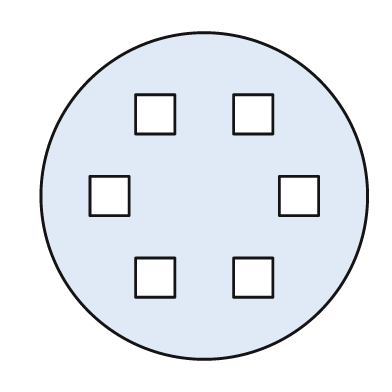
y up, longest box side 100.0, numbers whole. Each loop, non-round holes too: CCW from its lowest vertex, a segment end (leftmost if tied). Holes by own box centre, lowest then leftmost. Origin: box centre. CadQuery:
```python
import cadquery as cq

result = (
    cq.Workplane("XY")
    .moveTo(0.0, 0.0)
    .circle(50.0)
    .moveTo(-21.0, -31.0)
    .lineTo(-9.0, -31.0)
    .lineTo(-9.0, -19.0)
    .lineTo(-21.0, -19.0)
    .close()
    .moveTo(9.0, -31.0)
    .lineTo(21.0, -31.0)
    .lineTo(21.0, -19.0)
    .lineTo(9.0, -19.0)
    .close()
    .moveTo(-35.0, -6.0)
    .lineTo(-23.0, -6.0)
    .lineTo(-23.0, 6.0)
    .lineTo(-35.0, 6.0)
    .close()
    .moveTo(23.0, -6.0)
    .lineTo(35.0, -6.0)
    .lineTo(35.0, 6.0)
    .lineTo(23.0, 6.0)
    .close()
    .moveTo(-21.0, 19.0)
    .lineTo(-9.0, 19.0)
    .lineTo(-9.0, 31.0)
    .lineTo(-21.0, 31.0)
    .close()
    .moveTo(9.0, 19.0)
    .lineTo(21.0, 19.0)
    .lineTo(21.0, 31.0)
    .lineTo(9.0, 31.0)
    .close()
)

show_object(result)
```